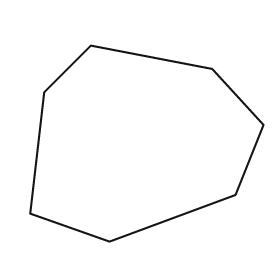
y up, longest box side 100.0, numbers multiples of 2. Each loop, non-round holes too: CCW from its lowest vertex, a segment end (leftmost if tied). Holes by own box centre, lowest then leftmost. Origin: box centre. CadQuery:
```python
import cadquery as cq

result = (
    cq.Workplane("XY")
    .moveTo(-16.0, -42.0)
    .lineTo(38.0, -22.0)
    .lineTo(50.0, 8.0)
    .lineTo(28.0, 32.0)
    .lineTo(-24.0, 42.0)
    .lineTo(-44.0, 22.0)
    .lineTo(-50.0, -30.0)
    .close()
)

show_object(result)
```